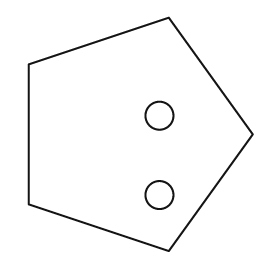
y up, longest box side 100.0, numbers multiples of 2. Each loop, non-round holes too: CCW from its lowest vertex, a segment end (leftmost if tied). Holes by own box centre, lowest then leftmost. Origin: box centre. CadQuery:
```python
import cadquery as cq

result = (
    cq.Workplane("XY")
    .moveTo(12.0, -50.0)
    .lineTo(48.0, 0.0)
    .lineTo(12.0, 50.0)
    .lineTo(-48.0, 30.0)
    .lineTo(-48.0, -30.0)
    .close()
    .moveTo(8.0, -26.0)
    .circle(6.0)
    .moveTo(8.0, 8.0)
    .circle(6.0)
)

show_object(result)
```